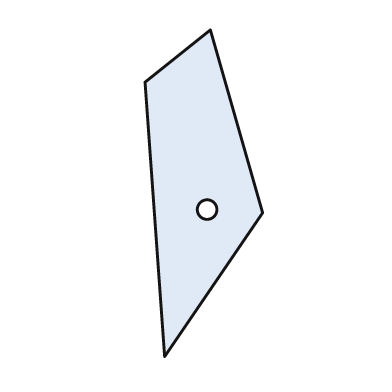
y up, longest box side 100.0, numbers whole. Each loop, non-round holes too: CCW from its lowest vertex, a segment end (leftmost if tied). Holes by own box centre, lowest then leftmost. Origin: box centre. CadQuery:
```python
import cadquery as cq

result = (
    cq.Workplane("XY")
    .moveTo(-12.0, -50.0)
    .lineTo(18.0, -6.0)
    .lineTo(2.0, 50.0)
    .lineTo(-18.0, 34.0)
    .close()
    .moveTo(1.0, -5.0)
    .circle(3.0)
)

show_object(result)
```